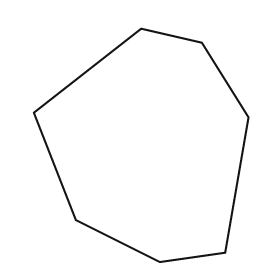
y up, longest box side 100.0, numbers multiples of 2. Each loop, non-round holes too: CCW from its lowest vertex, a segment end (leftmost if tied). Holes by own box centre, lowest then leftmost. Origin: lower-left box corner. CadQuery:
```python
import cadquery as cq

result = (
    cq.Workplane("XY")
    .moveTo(54.0, 0.0)
    .lineTo(82.0, 4.0)
    .lineTo(92.0, 62.0)
    .lineTo(72.0, 94.0)
    .lineTo(46.0, 100.0)
    .lineTo(0.0, 64.0)
    .lineTo(18.0, 18.0)
    .close()
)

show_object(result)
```